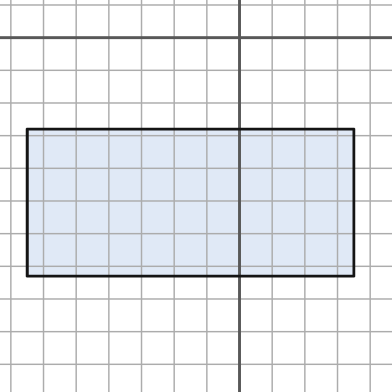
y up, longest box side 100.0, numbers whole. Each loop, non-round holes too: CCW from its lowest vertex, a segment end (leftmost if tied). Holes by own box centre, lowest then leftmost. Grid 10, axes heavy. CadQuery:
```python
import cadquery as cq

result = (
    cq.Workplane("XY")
    .moveTo(-65.0, -73.0)
    .lineTo(35.0, -73.0)
    .lineTo(35.0, -28.0)
    .lineTo(-65.0, -28.0)
    .close()
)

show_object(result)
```